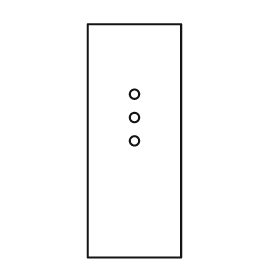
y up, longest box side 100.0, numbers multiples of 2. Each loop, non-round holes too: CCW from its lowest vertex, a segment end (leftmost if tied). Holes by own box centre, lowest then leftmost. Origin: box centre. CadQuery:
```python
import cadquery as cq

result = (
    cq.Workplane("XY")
    .moveTo(-20.0, -50.0)
    .lineTo(20.0, -50.0)
    .lineTo(20.0, 50.0)
    .lineTo(-20.0, 50.0)
    .close()
    .moveTo(0.0, 0.0)
    .circle(2.0)
    .moveTo(0.0, 10.0)
    .circle(2.0)
    .moveTo(0.0, 20.0)
    .circle(2.0)
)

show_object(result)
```